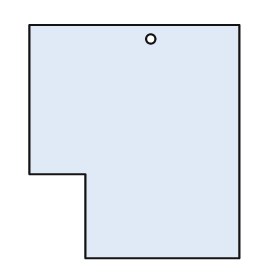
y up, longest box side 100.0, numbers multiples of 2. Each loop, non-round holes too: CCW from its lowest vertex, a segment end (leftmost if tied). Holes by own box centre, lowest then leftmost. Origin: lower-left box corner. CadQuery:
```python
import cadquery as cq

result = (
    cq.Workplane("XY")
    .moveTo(24.0, 0.0)
    .lineTo(90.0, 0.0)
    .lineTo(90.0, 100.0)
    .lineTo(0.0, 100.0)
    .lineTo(0.0, 36.0)
    .lineTo(24.0, 36.0)
    .close()
    .moveTo(52.0, 94.0)
    .circle(2.0)
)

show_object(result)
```